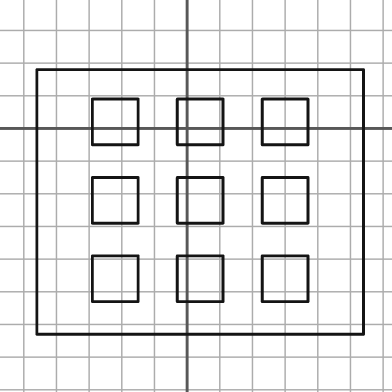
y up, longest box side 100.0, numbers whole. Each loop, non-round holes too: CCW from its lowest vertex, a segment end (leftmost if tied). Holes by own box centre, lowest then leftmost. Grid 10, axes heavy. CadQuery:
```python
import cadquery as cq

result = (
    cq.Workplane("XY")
    .moveTo(-46.0, -63.0)
    .lineTo(54.0, -63.0)
    .lineTo(54.0, 18.0)
    .lineTo(-46.0, 18.0)
    .close()
    .moveTo(-29.0, -53.0)
    .lineTo(-15.0, -53.0)
    .lineTo(-15.0, -39.0)
    .lineTo(-29.0, -39.0)
    .close()
    .moveTo(-3.0, -53.0)
    .lineTo(11.0, -53.0)
    .lineTo(11.0, -39.0)
    .lineTo(-3.0, -39.0)
    .close()
    .moveTo(23.0, -53.0)
    .lineTo(37.0, -53.0)
    .lineTo(37.0, -39.0)
    .lineTo(23.0, -39.0)
    .close()
    .moveTo(-29.0, -29.0)
    .lineTo(-15.0, -29.0)
    .lineTo(-15.0, -15.0)
    .lineTo(-29.0, -15.0)
    .close()
    .moveTo(-3.0, -29.0)
    .lineTo(11.0, -29.0)
    .lineTo(11.0, -15.0)
    .lineTo(-3.0, -15.0)
    .close()
    .moveTo(23.0, -29.0)
    .lineTo(37.0, -29.0)
    .lineTo(37.0, -15.0)
    .lineTo(23.0, -15.0)
    .close()
    .moveTo(-29.0, -5.0)
    .lineTo(-15.0, -5.0)
    .lineTo(-15.0, 9.0)
    .lineTo(-29.0, 9.0)
    .close()
    .moveTo(-3.0, -5.0)
    .lineTo(11.0, -5.0)
    .lineTo(11.0, 9.0)
    .lineTo(-3.0, 9.0)
    .close()
    .moveTo(23.0, -5.0)
    .lineTo(37.0, -5.0)
    .lineTo(37.0, 9.0)
    .lineTo(23.0, 9.0)
    .close()
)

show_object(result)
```